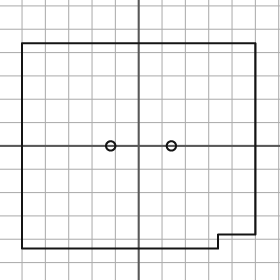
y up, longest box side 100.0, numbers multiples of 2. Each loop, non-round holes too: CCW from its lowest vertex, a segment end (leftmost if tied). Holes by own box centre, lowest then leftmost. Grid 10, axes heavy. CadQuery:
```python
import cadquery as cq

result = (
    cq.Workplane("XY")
    .moveTo(-50.0, -44.0)
    .lineTo(34.0, -44.0)
    .lineTo(34.0, -38.0)
    .lineTo(50.0, -38.0)
    .lineTo(50.0, 44.0)
    .lineTo(-50.0, 44.0)
    .close()
    .moveTo(-12.0, 0.0)
    .circle(2.0)
    .moveTo(14.0, 0.0)
    .circle(2.0)
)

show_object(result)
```